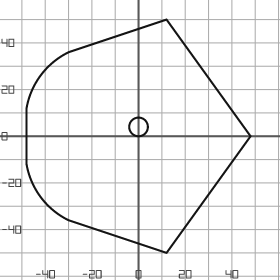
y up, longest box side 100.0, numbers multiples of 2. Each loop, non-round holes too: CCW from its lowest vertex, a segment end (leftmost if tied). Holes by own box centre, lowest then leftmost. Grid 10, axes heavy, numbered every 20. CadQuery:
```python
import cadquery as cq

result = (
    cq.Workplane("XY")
    .moveTo(12.0, -50.0)
    .lineTo(48.0, 0.0)
    .lineTo(12.0, 50.0)
    .lineTo(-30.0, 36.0)
    .threePointArc((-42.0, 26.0), (-48.0, 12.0))
    .lineTo(-48.0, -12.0)
    .threePointArc((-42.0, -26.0), (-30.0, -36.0))
    .close()
    .moveTo(0.0, 4.0)
    .circle(4.0)
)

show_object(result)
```